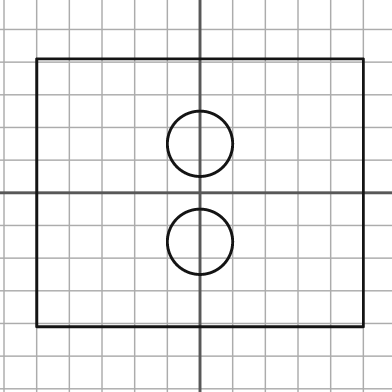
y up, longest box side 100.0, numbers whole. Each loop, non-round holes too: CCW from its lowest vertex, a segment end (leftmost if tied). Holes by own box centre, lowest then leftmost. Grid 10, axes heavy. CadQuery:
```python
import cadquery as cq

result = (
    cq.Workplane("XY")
    .moveTo(-50.0, -41.0)
    .lineTo(50.0, -41.0)
    .lineTo(50.0, 41.0)
    .lineTo(-50.0, 41.0)
    .close()
    .moveTo(0.0, -15.0)
    .circle(10.0)
    .moveTo(0.0, 15.0)
    .circle(10.0)
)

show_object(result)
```